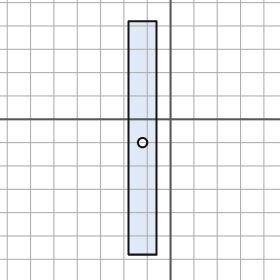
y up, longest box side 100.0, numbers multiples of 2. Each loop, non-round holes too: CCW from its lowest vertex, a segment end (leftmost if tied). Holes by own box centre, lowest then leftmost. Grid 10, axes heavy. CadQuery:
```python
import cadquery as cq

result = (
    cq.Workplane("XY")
    .moveTo(-18.0, -58.0)
    .lineTo(-6.0, -58.0)
    .lineTo(-6.0, 42.0)
    .lineTo(-18.0, 42.0)
    .close()
    .moveTo(-12.0, -10.0)
    .circle(2.0)
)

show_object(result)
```